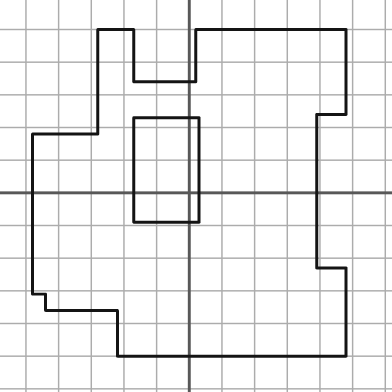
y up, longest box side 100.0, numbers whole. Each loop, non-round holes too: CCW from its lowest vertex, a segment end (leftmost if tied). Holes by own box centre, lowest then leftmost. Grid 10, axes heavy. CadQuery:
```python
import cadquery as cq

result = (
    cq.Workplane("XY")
    .moveTo(-22.0, -50.0)
    .lineTo(48.0, -50.0)
    .lineTo(48.0, -23.0)
    .lineTo(39.0, -23.0)
    .lineTo(39.0, 24.0)
    .lineTo(48.0, 24.0)
    .lineTo(48.0, 50.0)
    .lineTo(2.0, 50.0)
    .lineTo(2.0, 34.0)
    .lineTo(-17.0, 34.0)
    .lineTo(-17.0, 50.0)
    .lineTo(-28.0, 50.0)
    .lineTo(-28.0, 18.0)
    .lineTo(-48.0, 18.0)
    .lineTo(-48.0, -31.0)
    .lineTo(-44.0, -31.0)
    .lineTo(-44.0, -36.0)
    .lineTo(-22.0, -36.0)
    .close()
    .moveTo(-17.0, -9.0)
    .lineTo(3.0, -9.0)
    .lineTo(3.0, 23.0)
    .lineTo(-17.0, 23.0)
    .close()
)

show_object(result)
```